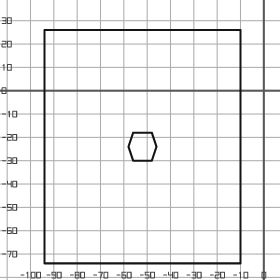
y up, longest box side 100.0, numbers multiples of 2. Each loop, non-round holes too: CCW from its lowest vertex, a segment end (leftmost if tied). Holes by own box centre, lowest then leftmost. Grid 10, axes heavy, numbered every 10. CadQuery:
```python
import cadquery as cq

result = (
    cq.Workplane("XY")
    .moveTo(-94.0, -74.0)
    .lineTo(-10.0, -74.0)
    .lineTo(-10.0, 26.0)
    .lineTo(-94.0, 26.0)
    .close()
    .moveTo(-56.0, -30.0)
    .lineTo(-48.0, -30.0)
    .lineTo(-46.0, -24.0)
    .lineTo(-48.0, -18.0)
    .lineTo(-56.0, -18.0)
    .lineTo(-58.0, -24.0)
    .close()
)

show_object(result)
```